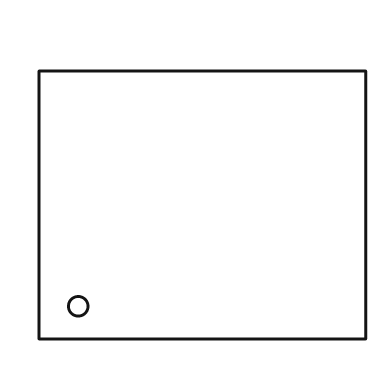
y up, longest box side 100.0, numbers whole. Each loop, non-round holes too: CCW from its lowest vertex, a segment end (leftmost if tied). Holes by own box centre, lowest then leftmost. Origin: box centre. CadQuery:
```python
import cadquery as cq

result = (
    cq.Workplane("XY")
    .moveTo(-50.0, -41.0)
    .lineTo(50.0, -41.0)
    .lineTo(50.0, 41.0)
    .lineTo(-50.0, 41.0)
    .close()
    .moveTo(-38.0, -31.0)
    .circle(3.0)
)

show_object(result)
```